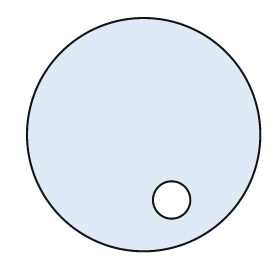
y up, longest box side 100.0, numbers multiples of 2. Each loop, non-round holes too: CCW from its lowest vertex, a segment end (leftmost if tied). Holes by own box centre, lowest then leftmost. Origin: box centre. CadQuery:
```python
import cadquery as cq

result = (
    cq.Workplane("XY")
    .moveTo(0.0, 0.0)
    .circle(50.0)
    .moveTo(12.0, -28.0)
    .circle(8.0)
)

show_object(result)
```